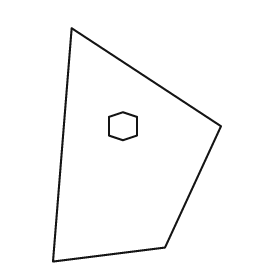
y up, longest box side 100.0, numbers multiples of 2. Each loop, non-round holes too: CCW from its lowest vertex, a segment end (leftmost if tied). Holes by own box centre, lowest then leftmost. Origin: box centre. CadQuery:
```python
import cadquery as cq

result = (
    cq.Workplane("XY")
    .moveTo(-36.0, -50.0)
    .lineTo(12.0, -44.0)
    .lineTo(36.0, 8.0)
    .lineTo(-28.0, 50.0)
    .close()
    .moveTo(-6.0, 2.0)
    .lineTo(0.0, 4.0)
    .lineTo(0.0, 12.0)
    .lineTo(-6.0, 14.0)
    .lineTo(-12.0, 12.0)
    .lineTo(-12.0, 4.0)
    .close()
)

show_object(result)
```